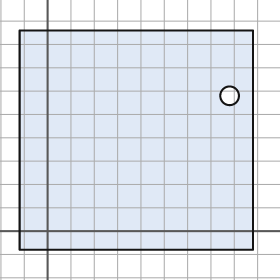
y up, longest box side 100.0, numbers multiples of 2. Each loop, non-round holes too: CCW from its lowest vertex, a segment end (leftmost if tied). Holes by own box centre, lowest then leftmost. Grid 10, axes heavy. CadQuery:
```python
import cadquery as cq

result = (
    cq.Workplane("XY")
    .moveTo(-12.0, -8.0)
    .lineTo(88.0, -8.0)
    .lineTo(88.0, 86.0)
    .lineTo(-12.0, 86.0)
    .close()
    .moveTo(78.0, 58.0)
    .circle(4.0)
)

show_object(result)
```